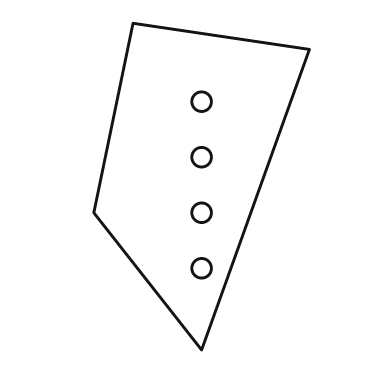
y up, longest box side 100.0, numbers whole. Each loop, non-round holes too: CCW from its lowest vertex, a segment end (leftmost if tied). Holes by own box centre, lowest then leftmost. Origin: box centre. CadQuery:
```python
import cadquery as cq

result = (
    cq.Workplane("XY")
    .moveTo(0.0, -50.0)
    .lineTo(33.0, 42.0)
    .lineTo(-21.0, 50.0)
    .lineTo(-33.0, -8.0)
    .close()
    .moveTo(0.0, -25.0)
    .circle(3.0)
    .moveTo(0.0, -8.0)
    .circle(3.0)
    .moveTo(0.0, 9.0)
    .circle(3.0)
    .moveTo(0.0, 26.0)
    .circle(3.0)
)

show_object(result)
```